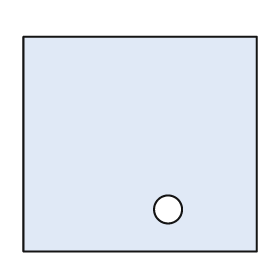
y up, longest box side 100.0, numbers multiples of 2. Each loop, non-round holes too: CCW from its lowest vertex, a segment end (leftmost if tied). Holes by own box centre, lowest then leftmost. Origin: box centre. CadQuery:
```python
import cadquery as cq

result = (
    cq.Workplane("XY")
    .moveTo(-50.0, -46.0)
    .lineTo(50.0, -46.0)
    .lineTo(50.0, 46.0)
    .lineTo(-50.0, 46.0)
    .close()
    .moveTo(12.0, -28.0)
    .circle(6.0)
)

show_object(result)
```